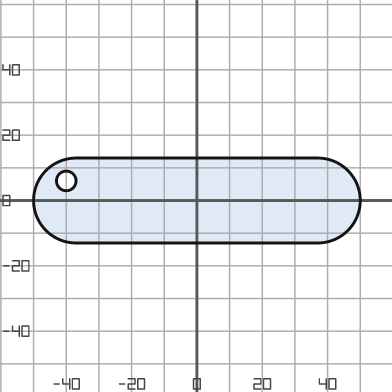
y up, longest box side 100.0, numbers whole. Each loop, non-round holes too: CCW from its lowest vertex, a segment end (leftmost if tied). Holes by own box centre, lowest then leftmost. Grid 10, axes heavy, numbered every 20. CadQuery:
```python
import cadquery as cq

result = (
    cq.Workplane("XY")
    .moveTo(-37.0, -13.0)
    .lineTo(37.0, -13.0)
    .threePointArc((50.0, 0.0), (37.0, 13.0))
    .lineTo(-37.0, 13.0)
    .threePointArc((-50.0, 0.0), (-37.0, -13.0))
    .close()
    .moveTo(-40.0, 6.0)
    .circle(3.0)
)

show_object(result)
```